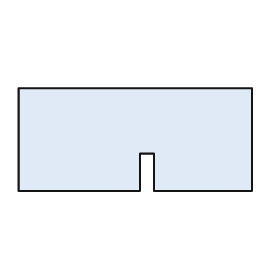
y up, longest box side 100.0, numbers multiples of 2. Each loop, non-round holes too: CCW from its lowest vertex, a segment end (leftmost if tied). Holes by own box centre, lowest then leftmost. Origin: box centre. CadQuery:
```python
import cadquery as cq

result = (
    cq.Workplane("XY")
    .moveTo(-50.0, -22.0)
    .lineTo(2.0, -22.0)
    .lineTo(2.0, -6.0)
    .lineTo(8.0, -6.0)
    .lineTo(8.0, -22.0)
    .lineTo(50.0, -22.0)
    .lineTo(50.0, 22.0)
    .lineTo(-50.0, 22.0)
    .close()
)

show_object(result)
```